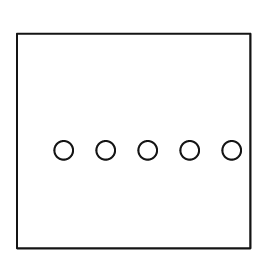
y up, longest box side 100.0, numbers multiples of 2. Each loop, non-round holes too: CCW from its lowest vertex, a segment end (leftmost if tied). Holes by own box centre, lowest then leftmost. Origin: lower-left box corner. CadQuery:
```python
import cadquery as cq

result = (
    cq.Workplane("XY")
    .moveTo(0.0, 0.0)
    .lineTo(100.0, 0.0)
    .lineTo(100.0, 92.0)
    .lineTo(0.0, 92.0)
    .close()
    .moveTo(20.0, 42.0)
    .circle(4.0)
    .moveTo(38.0, 42.0)
    .circle(4.0)
    .moveTo(56.0, 42.0)
    .circle(4.0)
    .moveTo(74.0, 42.0)
    .circle(4.0)
    .moveTo(92.0, 42.0)
    .circle(4.0)
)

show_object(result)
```